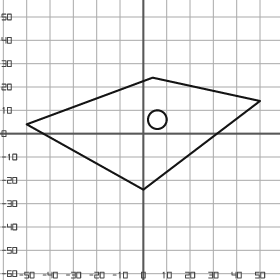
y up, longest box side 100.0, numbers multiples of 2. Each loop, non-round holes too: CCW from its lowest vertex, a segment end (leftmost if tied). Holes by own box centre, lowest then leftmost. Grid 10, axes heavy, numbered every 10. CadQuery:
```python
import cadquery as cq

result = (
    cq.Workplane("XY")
    .moveTo(0.0, -24.0)
    .lineTo(50.0, 14.0)
    .lineTo(4.0, 24.0)
    .lineTo(-50.0, 4.0)
    .close()
    .moveTo(6.0, 6.0)
    .circle(4.0)
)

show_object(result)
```